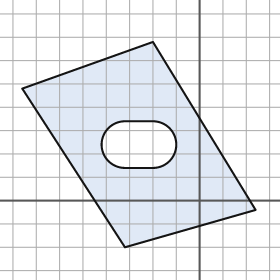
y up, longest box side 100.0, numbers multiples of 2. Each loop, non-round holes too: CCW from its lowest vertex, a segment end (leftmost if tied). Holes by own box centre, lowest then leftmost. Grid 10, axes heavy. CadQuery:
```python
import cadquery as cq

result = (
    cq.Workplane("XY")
    .moveTo(-32.0, -20.0)
    .lineTo(24.0, -4.0)
    .lineTo(-20.0, 68.0)
    .lineTo(-76.0, 48.0)
    .close()
    .moveTo(-32.0, 14.0)
    .lineTo(-20.0, 14.0)
    .threePointArc((-10.0, 24.0), (-20.0, 34.0))
    .lineTo(-32.0, 34.0)
    .threePointArc((-42.0, 24.0), (-32.0, 14.0))
    .close()
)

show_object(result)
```